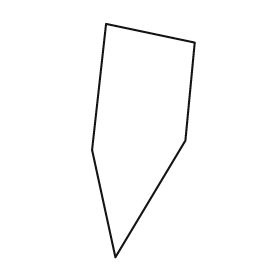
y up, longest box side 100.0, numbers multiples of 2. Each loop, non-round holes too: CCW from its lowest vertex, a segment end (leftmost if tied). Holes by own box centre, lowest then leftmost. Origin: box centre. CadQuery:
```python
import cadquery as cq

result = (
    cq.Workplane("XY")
    .moveTo(-12.0, -50.0)
    .lineTo(18.0, 0.0)
    .lineTo(22.0, 42.0)
    .lineTo(-16.0, 50.0)
    .lineTo(-22.0, -4.0)
    .close()
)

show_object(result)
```